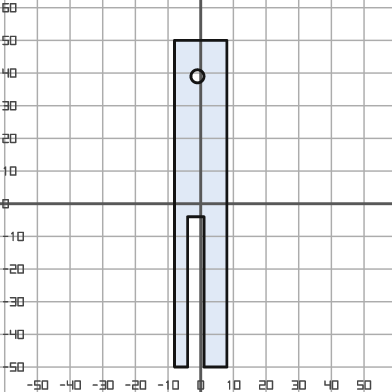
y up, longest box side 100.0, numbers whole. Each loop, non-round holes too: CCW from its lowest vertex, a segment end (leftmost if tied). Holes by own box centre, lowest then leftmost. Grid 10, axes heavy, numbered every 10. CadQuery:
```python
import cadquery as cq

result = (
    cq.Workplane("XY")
    .moveTo(-8.0, -50.0)
    .lineTo(-4.0, -50.0)
    .lineTo(-4.0, -4.0)
    .lineTo(1.0, -4.0)
    .lineTo(1.0, -50.0)
    .lineTo(8.0, -50.0)
    .lineTo(8.0, 50.0)
    .lineTo(-8.0, 50.0)
    .close()
    .moveTo(-1.0, 39.0)
    .circle(2.0)
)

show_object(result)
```